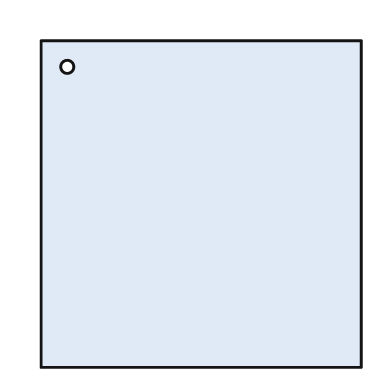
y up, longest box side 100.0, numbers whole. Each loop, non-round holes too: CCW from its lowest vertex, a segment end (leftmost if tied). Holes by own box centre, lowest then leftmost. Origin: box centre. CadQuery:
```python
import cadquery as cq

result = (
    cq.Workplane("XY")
    .moveTo(-49.0, -50.0)
    .lineTo(49.0, -50.0)
    .lineTo(49.0, 50.0)
    .lineTo(-49.0, 50.0)
    .close()
    .moveTo(-41.0, 42.0)
    .circle(2.0)
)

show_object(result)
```